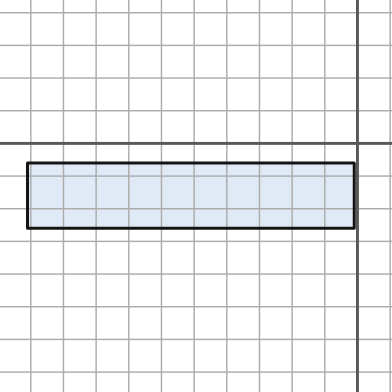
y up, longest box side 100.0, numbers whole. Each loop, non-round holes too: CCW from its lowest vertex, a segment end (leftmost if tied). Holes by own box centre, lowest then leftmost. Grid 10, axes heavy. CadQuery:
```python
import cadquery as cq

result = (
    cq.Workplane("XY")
    .moveTo(-101.0, -26.0)
    .lineTo(-1.0, -26.0)
    .lineTo(-1.0, -6.0)
    .lineTo(-101.0, -6.0)
    .close()
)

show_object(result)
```